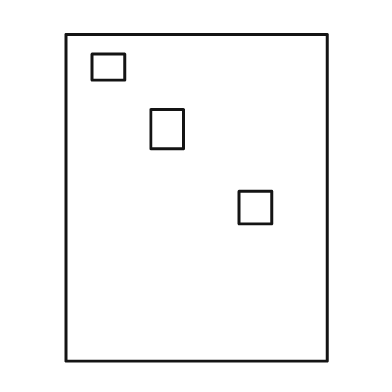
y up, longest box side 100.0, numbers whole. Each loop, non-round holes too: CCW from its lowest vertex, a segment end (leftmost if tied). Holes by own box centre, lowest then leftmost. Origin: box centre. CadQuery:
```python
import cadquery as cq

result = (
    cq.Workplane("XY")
    .moveTo(-40.0, -50.0)
    .lineTo(40.0, -50.0)
    .lineTo(40.0, 50.0)
    .lineTo(-40.0, 50.0)
    .close()
    .moveTo(13.0, -8.0)
    .lineTo(23.0, -8.0)
    .lineTo(23.0, 2.0)
    .lineTo(13.0, 2.0)
    .close()
    .moveTo(-14.0, 15.0)
    .lineTo(-4.0, 15.0)
    .lineTo(-4.0, 27.0)
    .lineTo(-14.0, 27.0)
    .close()
    .moveTo(-32.0, 36.0)
    .lineTo(-22.0, 36.0)
    .lineTo(-22.0, 44.0)
    .lineTo(-32.0, 44.0)
    .close()
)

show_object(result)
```